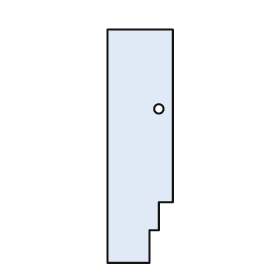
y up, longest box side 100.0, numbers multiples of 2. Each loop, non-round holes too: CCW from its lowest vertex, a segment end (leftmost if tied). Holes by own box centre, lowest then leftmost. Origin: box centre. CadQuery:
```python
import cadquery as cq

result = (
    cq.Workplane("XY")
    .moveTo(-14.0, -50.0)
    .lineTo(4.0, -50.0)
    .lineTo(4.0, -36.0)
    .lineTo(8.0, -36.0)
    .lineTo(8.0, -24.0)
    .lineTo(14.0, -24.0)
    .lineTo(14.0, 50.0)
    .lineTo(-14.0, 50.0)
    .close()
    .moveTo(8.0, 16.0)
    .circle(2.0)
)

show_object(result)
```